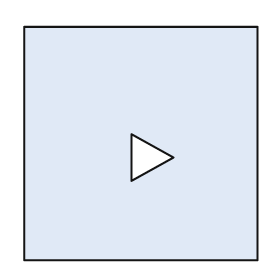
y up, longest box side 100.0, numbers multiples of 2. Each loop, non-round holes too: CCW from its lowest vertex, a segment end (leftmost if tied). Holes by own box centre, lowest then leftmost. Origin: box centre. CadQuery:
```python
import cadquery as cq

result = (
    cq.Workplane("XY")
    .moveTo(-50.0, -50.0)
    .lineTo(50.0, -50.0)
    .lineTo(50.0, 50.0)
    .lineTo(-50.0, 50.0)
    .close()
    .moveTo(-4.0, -16.0)
    .lineTo(14.0, -6.0)
    .lineTo(-4.0, 4.0)
    .close()
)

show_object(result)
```